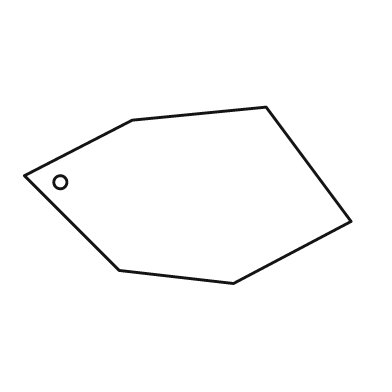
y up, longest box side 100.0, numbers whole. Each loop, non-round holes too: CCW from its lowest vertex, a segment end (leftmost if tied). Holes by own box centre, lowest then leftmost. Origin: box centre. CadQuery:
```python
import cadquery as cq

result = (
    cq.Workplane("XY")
    .moveTo(14.0, -27.0)
    .lineTo(50.0, -8.0)
    .lineTo(24.0, 27.0)
    .lineTo(-17.0, 23.0)
    .lineTo(-50.0, 6.0)
    .lineTo(-21.0, -23.0)
    .close()
    .moveTo(-39.0, 4.0)
    .circle(2.0)
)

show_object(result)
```